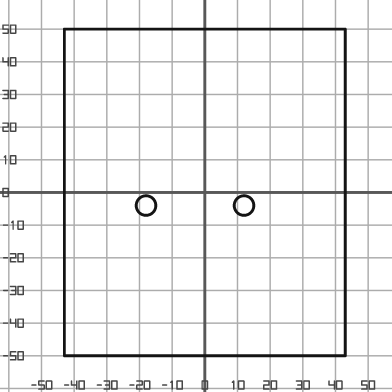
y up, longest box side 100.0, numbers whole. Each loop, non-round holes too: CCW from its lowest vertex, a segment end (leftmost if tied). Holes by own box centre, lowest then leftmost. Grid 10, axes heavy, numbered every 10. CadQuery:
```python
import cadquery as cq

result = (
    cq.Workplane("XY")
    .moveTo(-43.0, -50.0)
    .lineTo(43.0, -50.0)
    .lineTo(43.0, 50.0)
    .lineTo(-43.0, 50.0)
    .close()
    .moveTo(-18.0, -4.0)
    .circle(3.0)
    .moveTo(12.0, -4.0)
    .circle(3.0)
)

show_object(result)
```